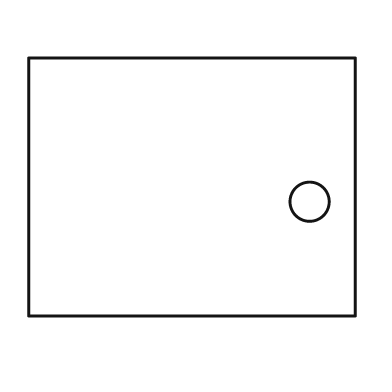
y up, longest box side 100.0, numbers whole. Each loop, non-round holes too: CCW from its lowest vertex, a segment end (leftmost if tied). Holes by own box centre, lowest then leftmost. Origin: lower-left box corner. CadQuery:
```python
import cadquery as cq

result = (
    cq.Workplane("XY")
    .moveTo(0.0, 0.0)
    .lineTo(100.0, 0.0)
    .lineTo(100.0, 79.0)
    .lineTo(0.0, 79.0)
    .close()
    .moveTo(86.0, 35.0)
    .circle(6.0)
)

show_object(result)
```